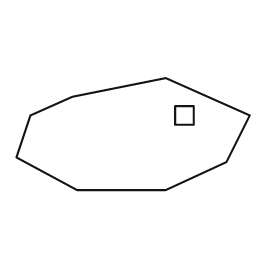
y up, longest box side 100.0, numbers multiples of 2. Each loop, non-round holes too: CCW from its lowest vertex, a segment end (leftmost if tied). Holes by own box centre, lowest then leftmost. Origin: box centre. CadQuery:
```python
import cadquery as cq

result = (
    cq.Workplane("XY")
    .moveTo(-24.0, -24.0)
    .lineTo(14.0, -24.0)
    .lineTo(40.0, -12.0)
    .lineTo(50.0, 8.0)
    .lineTo(14.0, 24.0)
    .lineTo(-26.0, 16.0)
    .lineTo(-44.0, 8.0)
    .lineTo(-50.0, -10.0)
    .close()
    .moveTo(18.0, 4.0)
    .lineTo(26.0, 4.0)
    .lineTo(26.0, 12.0)
    .lineTo(18.0, 12.0)
    .close()
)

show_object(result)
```